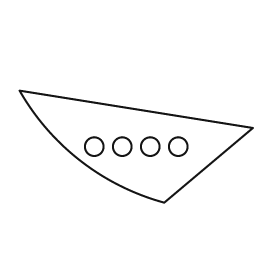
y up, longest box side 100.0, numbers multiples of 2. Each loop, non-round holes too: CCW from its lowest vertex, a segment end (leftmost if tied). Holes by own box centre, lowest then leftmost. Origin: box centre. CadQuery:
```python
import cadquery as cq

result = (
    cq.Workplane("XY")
    .moveTo(12.0, -24.0)
    .lineTo(50.0, 8.0)
    .lineTo(-50.0, 24.0)
    .threePointArc((-24.0, -6.0), (12.0, -24.0))
    .close()
    .moveTo(-18.0, 0.0)
    .circle(4.0)
    .moveTo(-6.0, 0.0)
    .circle(4.0)
    .moveTo(6.0, 0.0)
    .circle(4.0)
    .moveTo(18.0, 0.0)
    .circle(4.0)
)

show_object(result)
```